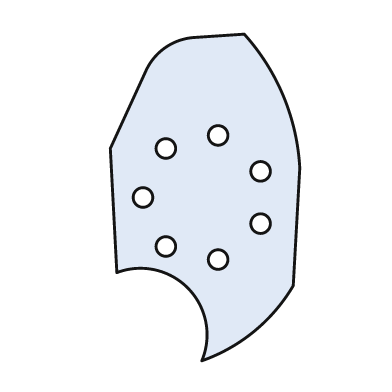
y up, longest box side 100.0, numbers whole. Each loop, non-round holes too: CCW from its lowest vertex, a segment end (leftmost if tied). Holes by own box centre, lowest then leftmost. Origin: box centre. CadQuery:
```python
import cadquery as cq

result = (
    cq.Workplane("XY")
    .moveTo(-1.0, -50.0)
    .threePointArc((15.0, -41.0), (27.0, -27.0))
    .lineTo(29.0, 9.0)
    .threePointArc((24.0, 31.0), (12.0, 50.0))
    .lineTo(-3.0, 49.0)
    .threePointArc((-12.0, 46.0), (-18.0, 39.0))
    .lineTo(-29.0, 15.0)
    .lineTo(-27.0, -23.0)
    .threePointArc((-5.0, -28.0), (-1.0, -50.0))
    .close()
    .moveTo(4.0, -19.0)
    .circle(3.0)
    .moveTo(-12.0, -15.0)
    .circle(3.0)
    .moveTo(17.0, -8.0)
    .circle(3.0)
    .moveTo(-19.0, 0.0)
    .circle(3.0)
    .moveTo(17.0, 8.0)
    .circle(3.0)
    .moveTo(-12.0, 15.0)
    .circle(3.0)
    .moveTo(4.0, 19.0)
    .circle(3.0)
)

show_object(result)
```